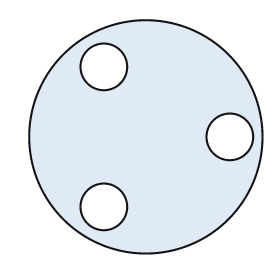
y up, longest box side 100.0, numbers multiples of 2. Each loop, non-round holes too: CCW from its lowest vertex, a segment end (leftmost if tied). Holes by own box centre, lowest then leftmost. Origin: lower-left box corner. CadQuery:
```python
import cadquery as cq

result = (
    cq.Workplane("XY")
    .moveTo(50.0, 50.0)
    .circle(50.0)
    .moveTo(32.0, 20.0)
    .circle(10.0)
    .moveTo(86.0, 50.0)
    .circle(10.0)
    .moveTo(32.0, 80.0)
    .circle(10.0)
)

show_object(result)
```